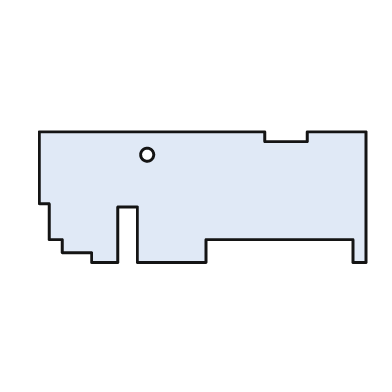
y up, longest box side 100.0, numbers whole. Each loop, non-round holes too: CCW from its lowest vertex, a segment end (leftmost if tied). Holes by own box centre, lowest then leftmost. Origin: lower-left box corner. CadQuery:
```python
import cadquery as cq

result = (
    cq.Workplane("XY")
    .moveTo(16.0, 0.0)
    .lineTo(24.0, 0.0)
    .lineTo(24.0, 17.0)
    .lineTo(30.0, 17.0)
    .lineTo(30.0, 0.0)
    .lineTo(51.0, 0.0)
    .lineTo(51.0, 7.0)
    .lineTo(96.0, 7.0)
    .lineTo(96.0, 0.0)
    .lineTo(100.0, 0.0)
    .lineTo(100.0, 40.0)
    .lineTo(82.0, 40.0)
    .lineTo(82.0, 37.0)
    .lineTo(69.0, 37.0)
    .lineTo(69.0, 40.0)
    .lineTo(0.0, 40.0)
    .lineTo(0.0, 18.0)
    .lineTo(3.0, 18.0)
    .lineTo(3.0, 7.0)
    .lineTo(7.0, 7.0)
    .lineTo(7.0, 3.0)
    .lineTo(16.0, 3.0)
    .close()
    .moveTo(33.0, 33.0)
    .circle(2.0)
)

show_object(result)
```